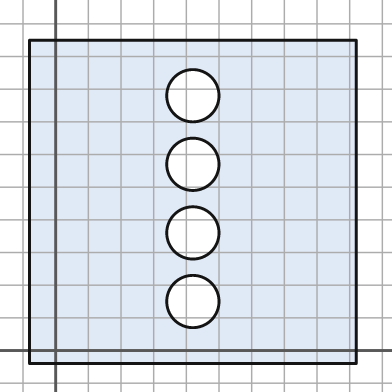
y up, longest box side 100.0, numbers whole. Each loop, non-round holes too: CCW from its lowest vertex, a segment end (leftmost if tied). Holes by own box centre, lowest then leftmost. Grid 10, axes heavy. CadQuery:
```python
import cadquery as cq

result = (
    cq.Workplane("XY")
    .moveTo(-8.0, -4.0)
    .lineTo(92.0, -4.0)
    .lineTo(92.0, 95.0)
    .lineTo(-8.0, 95.0)
    .close()
    .moveTo(42.0, 15.0)
    .circle(8.0)
    .moveTo(42.0, 36.0)
    .circle(8.0)
    .moveTo(42.0, 57.0)
    .circle(8.0)
    .moveTo(42.0, 78.0)
    .circle(8.0)
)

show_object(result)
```